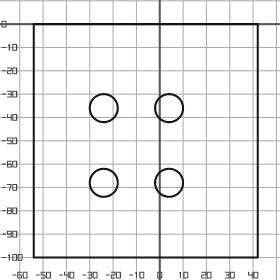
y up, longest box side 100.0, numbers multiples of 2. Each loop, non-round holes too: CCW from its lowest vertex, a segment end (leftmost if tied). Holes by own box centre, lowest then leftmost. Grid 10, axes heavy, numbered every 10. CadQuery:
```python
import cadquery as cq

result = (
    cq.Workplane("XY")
    .moveTo(-54.0, -100.0)
    .lineTo(42.0, -100.0)
    .lineTo(42.0, 0.0)
    .lineTo(-54.0, 0.0)
    .close()
    .moveTo(-24.0, -68.0)
    .circle(6.0)
    .moveTo(4.0, -68.0)
    .circle(6.0)
    .moveTo(-24.0, -36.0)
    .circle(6.0)
    .moveTo(4.0, -36.0)
    .circle(6.0)
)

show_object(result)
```